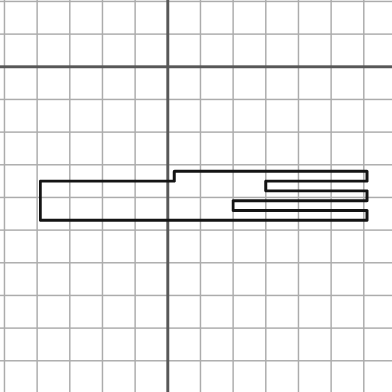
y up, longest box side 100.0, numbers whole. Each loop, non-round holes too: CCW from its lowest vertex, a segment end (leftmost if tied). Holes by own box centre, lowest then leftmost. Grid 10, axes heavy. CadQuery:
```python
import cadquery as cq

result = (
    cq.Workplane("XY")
    .moveTo(-39.0, -47.0)
    .lineTo(61.0, -47.0)
    .lineTo(61.0, -44.0)
    .lineTo(20.0, -44.0)
    .lineTo(20.0, -41.0)
    .lineTo(61.0, -41.0)
    .lineTo(61.0, -38.0)
    .lineTo(30.0, -38.0)
    .lineTo(30.0, -35.0)
    .lineTo(61.0, -35.0)
    .lineTo(61.0, -32.0)
    .lineTo(2.0, -32.0)
    .lineTo(2.0, -35.0)
    .lineTo(-39.0, -35.0)
    .close()
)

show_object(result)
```